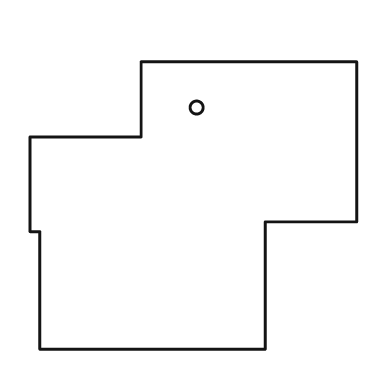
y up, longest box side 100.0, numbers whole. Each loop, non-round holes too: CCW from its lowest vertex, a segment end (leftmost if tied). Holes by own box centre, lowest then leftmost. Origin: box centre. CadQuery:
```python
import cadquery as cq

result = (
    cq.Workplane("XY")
    .moveTo(-47.0, -44.0)
    .lineTo(22.0, -44.0)
    .lineTo(22.0, -5.0)
    .lineTo(50.0, -5.0)
    .lineTo(50.0, 44.0)
    .lineTo(-16.0, 44.0)
    .lineTo(-16.0, 21.0)
    .lineTo(-50.0, 21.0)
    .lineTo(-50.0, -8.0)
    .lineTo(-47.0, -8.0)
    .close()
    .moveTo(1.0, 30.0)
    .circle(2.0)
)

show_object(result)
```